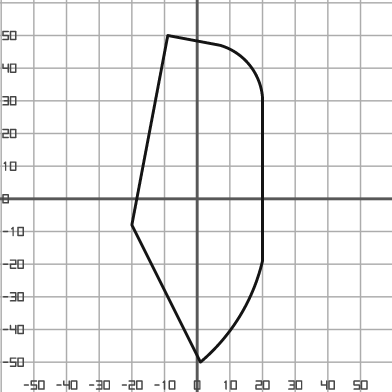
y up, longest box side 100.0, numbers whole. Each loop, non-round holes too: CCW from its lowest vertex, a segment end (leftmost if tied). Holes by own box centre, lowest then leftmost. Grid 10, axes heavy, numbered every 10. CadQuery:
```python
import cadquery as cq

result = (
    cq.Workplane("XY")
    .moveTo(1.0, -50.0)
    .threePointArc((13.0, -36.0), (20.0, -19.0))
    .lineTo(20.0, 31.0)
    .threePointArc((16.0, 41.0), (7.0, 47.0))
    .lineTo(-9.0, 50.0)
    .lineTo(-20.0, -8.0)
    .close()
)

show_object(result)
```